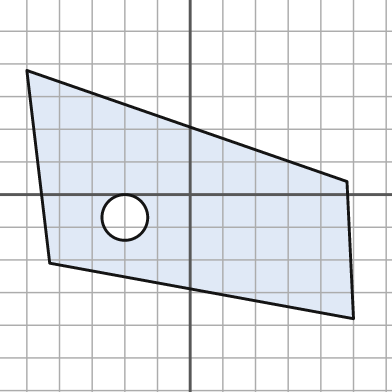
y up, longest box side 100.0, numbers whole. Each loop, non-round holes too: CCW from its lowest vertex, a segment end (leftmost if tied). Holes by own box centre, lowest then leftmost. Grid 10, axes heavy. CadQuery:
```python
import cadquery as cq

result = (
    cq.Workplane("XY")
    .moveTo(50.0, -38.0)
    .lineTo(48.0, 4.0)
    .lineTo(-50.0, 38.0)
    .lineTo(-43.0, -21.0)
    .close()
    .moveTo(-20.0, -7.0)
    .circle(7.0)
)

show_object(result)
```